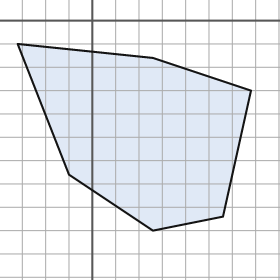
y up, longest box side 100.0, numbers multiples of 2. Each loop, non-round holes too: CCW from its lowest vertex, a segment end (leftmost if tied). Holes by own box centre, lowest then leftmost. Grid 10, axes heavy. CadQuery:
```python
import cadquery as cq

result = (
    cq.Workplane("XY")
    .moveTo(26.0, -90.0)
    .lineTo(56.0, -84.0)
    .lineTo(68.0, -30.0)
    .lineTo(26.0, -16.0)
    .lineTo(-32.0, -10.0)
    .lineTo(-10.0, -66.0)
    .close()
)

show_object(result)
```